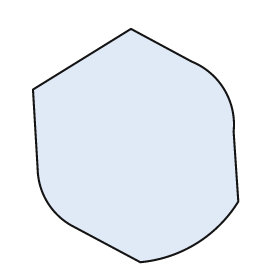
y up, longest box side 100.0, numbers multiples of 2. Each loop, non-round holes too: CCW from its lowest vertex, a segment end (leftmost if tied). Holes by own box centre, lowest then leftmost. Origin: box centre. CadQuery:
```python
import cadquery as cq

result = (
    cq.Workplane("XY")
    .moveTo(2.0, -50.0)
    .threePointArc((26.0, -42.0), (44.0, -24.0))
    .lineTo(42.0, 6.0)
    .threePointArc((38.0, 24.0), (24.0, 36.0))
    .lineTo(-2.0, 50.0)
    .lineTo(-44.0, 24.0)
    .lineTo(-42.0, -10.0)
    .threePointArc((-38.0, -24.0), (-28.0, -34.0))
    .close()
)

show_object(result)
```